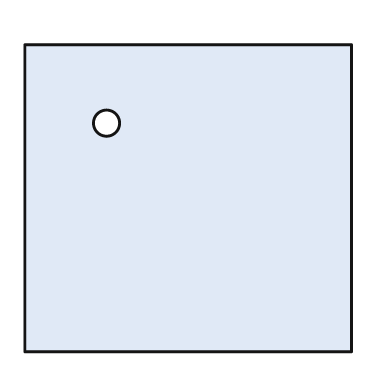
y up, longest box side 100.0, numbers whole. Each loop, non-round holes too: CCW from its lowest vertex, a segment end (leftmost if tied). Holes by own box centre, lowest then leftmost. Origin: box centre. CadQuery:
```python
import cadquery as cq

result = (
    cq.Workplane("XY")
    .moveTo(-50.0, -47.0)
    .lineTo(50.0, -47.0)
    .lineTo(50.0, 47.0)
    .lineTo(-50.0, 47.0)
    .close()
    .moveTo(-25.0, 23.0)
    .circle(4.0)
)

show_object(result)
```